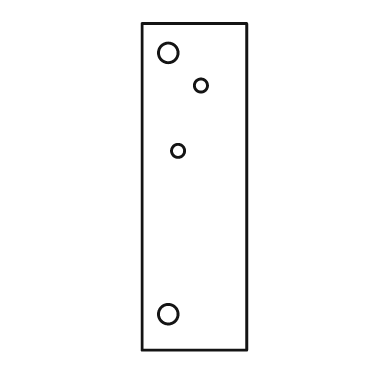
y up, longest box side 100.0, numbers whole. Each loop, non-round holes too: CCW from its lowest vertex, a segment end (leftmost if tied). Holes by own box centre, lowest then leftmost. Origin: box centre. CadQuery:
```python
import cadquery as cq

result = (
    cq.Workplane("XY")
    .moveTo(-16.0, -50.0)
    .lineTo(16.0, -50.0)
    .lineTo(16.0, 50.0)
    .lineTo(-16.0, 50.0)
    .close()
    .moveTo(-8.0, -39.0)
    .circle(3.0)
    .moveTo(-5.0, 11.0)
    .circle(2.0)
    .moveTo(2.0, 31.0)
    .circle(2.0)
    .moveTo(-8.0, 41.0)
    .circle(3.0)
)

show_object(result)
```